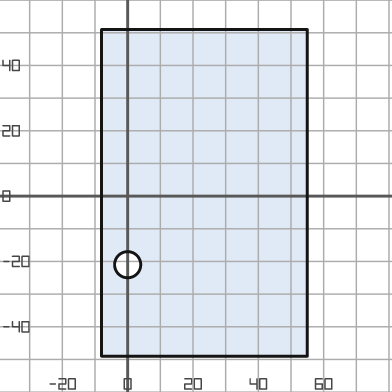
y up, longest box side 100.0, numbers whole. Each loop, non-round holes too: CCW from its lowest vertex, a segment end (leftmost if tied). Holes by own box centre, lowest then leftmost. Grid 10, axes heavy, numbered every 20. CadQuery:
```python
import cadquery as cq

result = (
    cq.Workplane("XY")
    .moveTo(-8.0, -49.0)
    .lineTo(55.0, -49.0)
    .lineTo(55.0, 51.0)
    .lineTo(-8.0, 51.0)
    .close()
    .moveTo(0.0, -21.0)
    .circle(4.0)
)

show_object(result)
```